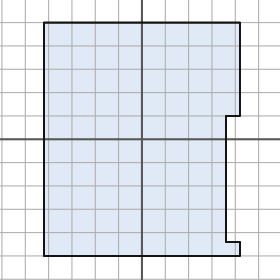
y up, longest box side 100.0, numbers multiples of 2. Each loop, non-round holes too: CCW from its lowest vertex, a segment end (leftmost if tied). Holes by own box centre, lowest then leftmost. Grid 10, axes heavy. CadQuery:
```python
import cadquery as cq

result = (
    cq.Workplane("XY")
    .moveTo(-42.0, -50.0)
    .lineTo(42.0, -50.0)
    .lineTo(42.0, -44.0)
    .lineTo(36.0, -44.0)
    .lineTo(36.0, 10.0)
    .lineTo(42.0, 10.0)
    .lineTo(42.0, 50.0)
    .lineTo(-42.0, 50.0)
    .close()
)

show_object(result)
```